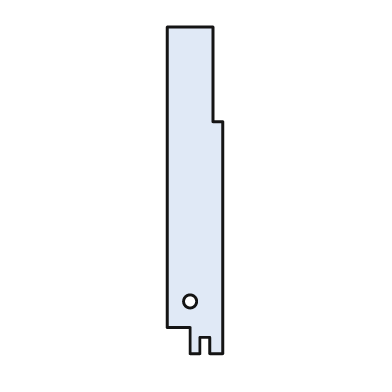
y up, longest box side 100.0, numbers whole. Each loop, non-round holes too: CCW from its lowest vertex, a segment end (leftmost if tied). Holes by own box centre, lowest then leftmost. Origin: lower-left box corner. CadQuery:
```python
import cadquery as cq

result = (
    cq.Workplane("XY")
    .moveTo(7.0, 0.0)
    .lineTo(10.0, 0.0)
    .lineTo(10.0, 5.0)
    .lineTo(13.0, 5.0)
    .lineTo(13.0, 0.0)
    .lineTo(17.0, 0.0)
    .lineTo(17.0, 71.0)
    .lineTo(14.0, 71.0)
    .lineTo(14.0, 100.0)
    .lineTo(0.0, 100.0)
    .lineTo(0.0, 8.0)
    .lineTo(7.0, 8.0)
    .close()
    .moveTo(7.0, 16.0)
    .circle(2.0)
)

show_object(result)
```